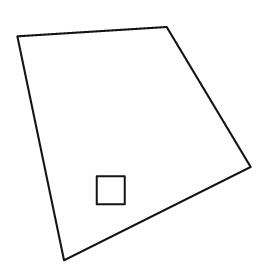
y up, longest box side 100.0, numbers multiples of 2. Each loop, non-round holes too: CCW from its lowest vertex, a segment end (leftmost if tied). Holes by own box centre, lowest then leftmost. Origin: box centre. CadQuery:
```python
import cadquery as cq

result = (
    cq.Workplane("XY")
    .moveTo(-30.0, -50.0)
    .lineTo(50.0, -10.0)
    .lineTo(14.0, 50.0)
    .lineTo(-50.0, 46.0)
    .close()
    .moveTo(-16.0, -26.0)
    .lineTo(-4.0, -26.0)
    .lineTo(-4.0, -14.0)
    .lineTo(-16.0, -14.0)
    .close()
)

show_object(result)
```